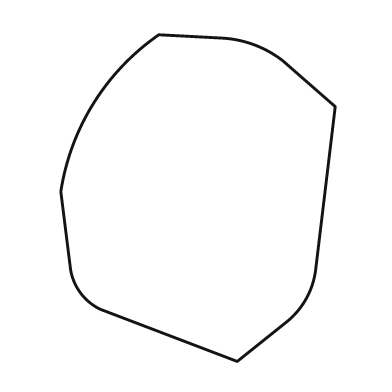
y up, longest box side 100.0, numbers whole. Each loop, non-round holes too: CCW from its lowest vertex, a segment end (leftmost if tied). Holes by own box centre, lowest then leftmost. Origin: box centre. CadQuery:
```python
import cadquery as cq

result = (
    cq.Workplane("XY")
    .moveTo(12.0, -50.0)
    .lineTo(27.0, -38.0)
    .threePointArc((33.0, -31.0), (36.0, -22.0))
    .lineTo(42.0, 28.0)
    .lineTo(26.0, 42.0)
    .threePointArc((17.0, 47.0), (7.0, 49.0))
    .lineTo(-12.0, 50.0)
    .threePointArc((-32.0, 29.0), (-42.0, 2.0))
    .lineTo(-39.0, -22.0)
    .threePointArc((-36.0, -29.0), (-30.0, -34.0))
    .close()
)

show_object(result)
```